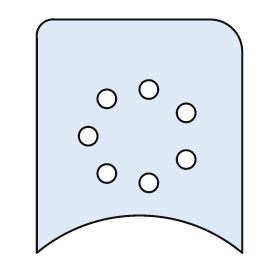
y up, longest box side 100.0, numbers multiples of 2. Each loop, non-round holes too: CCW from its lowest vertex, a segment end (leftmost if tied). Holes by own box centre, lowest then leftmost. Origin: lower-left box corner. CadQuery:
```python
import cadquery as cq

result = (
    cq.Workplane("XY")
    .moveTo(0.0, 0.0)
    .threePointArc((44.0, 16.0), (88.0, 0.0))
    .lineTo(88.0, 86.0)
    .threePointArc((84.0, 96.0), (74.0, 100.0))
    .lineTo(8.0, 100.0)
    .threePointArc((2.0, 98.0), (0.0, 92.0))
    .close()
    .moveTo(48.0, 30.0)
    .circle(4.0)
    .moveTo(30.0, 34.0)
    .circle(4.0)
    .moveTo(64.0, 40.0)
    .circle(4.0)
    .moveTo(22.0, 50.0)
    .circle(4.0)
    .moveTo(64.0, 60.0)
    .circle(4.0)
    .moveTo(30.0, 66.0)
    .circle(4.0)
    .moveTo(48.0, 70.0)
    .circle(4.0)
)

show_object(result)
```